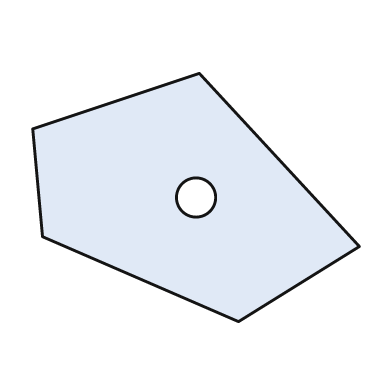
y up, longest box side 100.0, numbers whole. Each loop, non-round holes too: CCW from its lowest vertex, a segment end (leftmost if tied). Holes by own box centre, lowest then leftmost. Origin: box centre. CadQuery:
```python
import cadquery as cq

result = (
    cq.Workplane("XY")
    .moveTo(13.0, -38.0)
    .lineTo(50.0, -15.0)
    .lineTo(1.0, 38.0)
    .lineTo(-50.0, 21.0)
    .lineTo(-47.0, -12.0)
    .close()
    .moveTo(0.0, 0.0)
    .circle(6.0)
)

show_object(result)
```